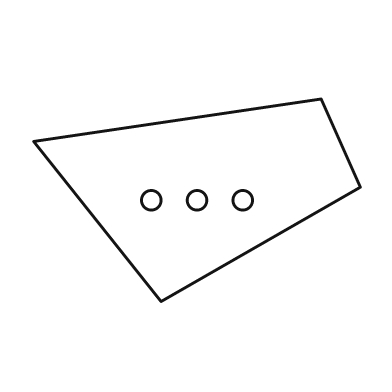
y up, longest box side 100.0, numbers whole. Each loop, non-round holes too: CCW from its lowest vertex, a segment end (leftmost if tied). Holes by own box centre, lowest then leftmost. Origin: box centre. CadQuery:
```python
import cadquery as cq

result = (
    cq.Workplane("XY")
    .moveTo(-11.0, -31.0)
    .lineTo(50.0, 4.0)
    .lineTo(38.0, 31.0)
    .lineTo(-50.0, 18.0)
    .close()
    .moveTo(-14.0, 0.0)
    .circle(3.0)
    .moveTo(0.0, 0.0)
    .circle(3.0)
    .moveTo(14.0, 0.0)
    .circle(3.0)
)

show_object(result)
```